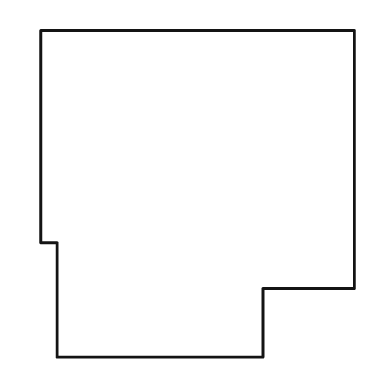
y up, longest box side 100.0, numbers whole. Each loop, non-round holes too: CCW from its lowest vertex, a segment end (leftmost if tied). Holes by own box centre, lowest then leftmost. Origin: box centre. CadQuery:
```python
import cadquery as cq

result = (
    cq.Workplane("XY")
    .moveTo(-43.0, -50.0)
    .lineTo(20.0, -50.0)
    .lineTo(20.0, -29.0)
    .lineTo(48.0, -29.0)
    .lineTo(48.0, 50.0)
    .lineTo(-48.0, 50.0)
    .lineTo(-48.0, -15.0)
    .lineTo(-43.0, -15.0)
    .close()
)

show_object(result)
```